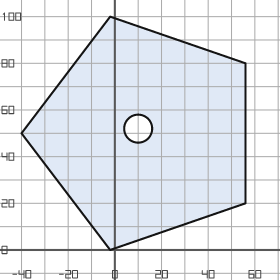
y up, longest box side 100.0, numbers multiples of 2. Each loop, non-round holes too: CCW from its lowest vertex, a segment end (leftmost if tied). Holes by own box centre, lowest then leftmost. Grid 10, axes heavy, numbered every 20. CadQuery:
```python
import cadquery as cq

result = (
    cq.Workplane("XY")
    .moveTo(-2.0, 0.0)
    .lineTo(56.0, 20.0)
    .lineTo(56.0, 80.0)
    .lineTo(-2.0, 100.0)
    .lineTo(-40.0, 50.0)
    .close()
    .moveTo(10.0, 52.0)
    .circle(6.0)
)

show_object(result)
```